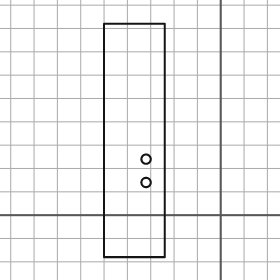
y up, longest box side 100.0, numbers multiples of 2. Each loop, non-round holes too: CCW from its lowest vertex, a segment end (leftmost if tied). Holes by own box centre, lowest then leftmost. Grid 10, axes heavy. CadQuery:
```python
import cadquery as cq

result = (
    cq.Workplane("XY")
    .moveTo(-50.0, -18.0)
    .lineTo(-24.0, -18.0)
    .lineTo(-24.0, 82.0)
    .lineTo(-50.0, 82.0)
    .close()
    .moveTo(-32.0, 14.0)
    .circle(2.0)
    .moveTo(-32.0, 24.0)
    .circle(2.0)
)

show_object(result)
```